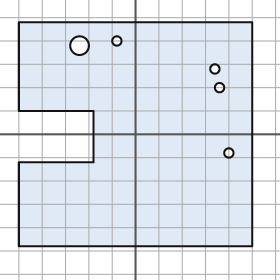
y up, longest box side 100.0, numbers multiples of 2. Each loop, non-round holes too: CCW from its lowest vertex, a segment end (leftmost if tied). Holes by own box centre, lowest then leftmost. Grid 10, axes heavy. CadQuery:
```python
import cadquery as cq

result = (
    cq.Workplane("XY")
    .moveTo(-50.0, -48.0)
    .lineTo(50.0, -48.0)
    .lineTo(50.0, 48.0)
    .lineTo(-50.0, 48.0)
    .lineTo(-50.0, 10.0)
    .lineTo(-18.0, 10.0)
    .lineTo(-18.0, -12.0)
    .lineTo(-50.0, -12.0)
    .close()
    .moveTo(40.0, -8.0)
    .circle(2.0)
    .moveTo(36.0, 20.0)
    .circle(2.0)
    .moveTo(34.0, 28.0)
    .circle(2.0)
    .moveTo(-24.0, 38.0)
    .circle(4.0)
    .moveTo(-8.0, 40.0)
    .circle(2.0)
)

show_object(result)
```